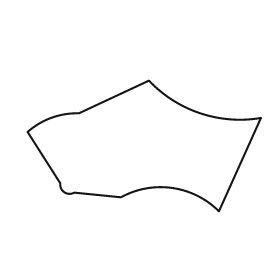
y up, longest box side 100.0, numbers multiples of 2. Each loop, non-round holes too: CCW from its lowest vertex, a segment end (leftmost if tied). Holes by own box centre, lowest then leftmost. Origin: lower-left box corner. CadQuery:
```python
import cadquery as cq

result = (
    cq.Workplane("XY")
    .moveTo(82.0, 0.0)
    .lineTo(100.0, 40.0)
    .threePointArc((74.0, 42.0), (52.0, 56.0))
    .lineTo(22.0, 42.0)
    .threePointArc((10.0, 40.0), (0.0, 34.0))
    .lineTo(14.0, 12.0)
    .threePointArc((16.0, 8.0), (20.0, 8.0))
    .lineTo(40.0, 6.0)
    .threePointArc((62.0, 10.0), (82.0, 0.0))
    .close()
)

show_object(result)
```